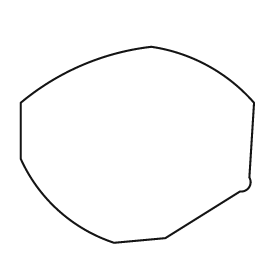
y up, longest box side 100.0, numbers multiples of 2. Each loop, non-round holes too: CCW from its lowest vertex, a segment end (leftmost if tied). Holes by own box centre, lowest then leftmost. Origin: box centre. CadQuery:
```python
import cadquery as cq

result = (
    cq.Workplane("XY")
    .moveTo(-10.0, -42.0)
    .lineTo(12.0, -40.0)
    .lineTo(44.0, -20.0)
    .threePointArc((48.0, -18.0), (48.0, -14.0))
    .lineTo(50.0, 18.0)
    .threePointArc((30.0, 34.0), (6.0, 42.0))
    .threePointArc((-24.0, 34.0), (-50.0, 18.0))
    .lineTo(-50.0, -6.0)
    .threePointArc((-34.0, -28.0), (-10.0, -42.0))
    .close()
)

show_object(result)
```